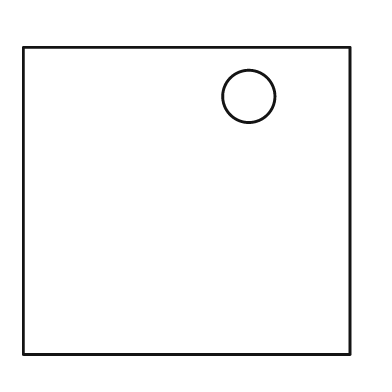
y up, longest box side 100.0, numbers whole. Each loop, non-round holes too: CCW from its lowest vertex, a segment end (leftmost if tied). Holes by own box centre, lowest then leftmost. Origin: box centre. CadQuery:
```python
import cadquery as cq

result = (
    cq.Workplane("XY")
    .moveTo(-50.0, -47.0)
    .lineTo(50.0, -47.0)
    .lineTo(50.0, 47.0)
    .lineTo(-50.0, 47.0)
    .close()
    .moveTo(19.0, 32.0)
    .circle(8.0)
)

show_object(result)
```